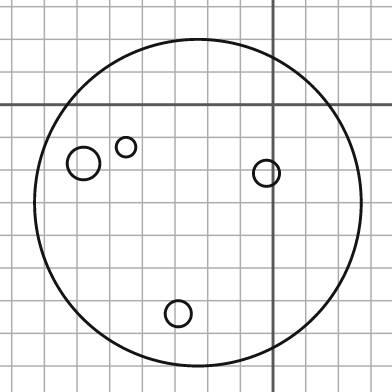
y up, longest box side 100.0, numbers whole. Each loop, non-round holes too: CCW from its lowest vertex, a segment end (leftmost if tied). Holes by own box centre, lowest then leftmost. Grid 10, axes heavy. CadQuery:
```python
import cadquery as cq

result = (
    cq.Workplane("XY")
    .moveTo(-23.0, -30.0)
    .circle(50.0)
    .moveTo(-29.0, -64.0)
    .circle(4.0)
    .moveTo(-2.0, -21.0)
    .circle(4.0)
    .moveTo(-58.0, -18.0)
    .circle(5.0)
    .moveTo(-45.0, -13.0)
    .circle(3.0)
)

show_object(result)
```